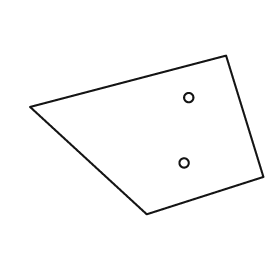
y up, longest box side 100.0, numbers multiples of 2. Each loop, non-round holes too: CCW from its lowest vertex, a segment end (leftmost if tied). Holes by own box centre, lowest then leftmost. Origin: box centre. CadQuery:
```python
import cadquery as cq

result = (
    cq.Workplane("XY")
    .moveTo(0.0, -34.0)
    .lineTo(50.0, -18.0)
    .lineTo(34.0, 34.0)
    .lineTo(-50.0, 12.0)
    .close()
    .moveTo(16.0, -12.0)
    .circle(2.0)
    .moveTo(18.0, 16.0)
    .circle(2.0)
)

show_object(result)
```